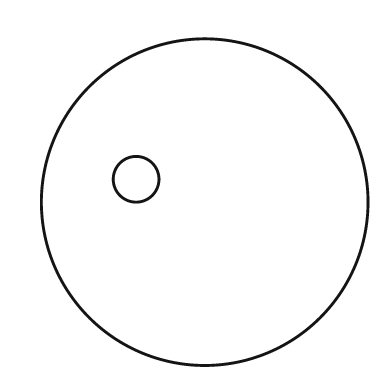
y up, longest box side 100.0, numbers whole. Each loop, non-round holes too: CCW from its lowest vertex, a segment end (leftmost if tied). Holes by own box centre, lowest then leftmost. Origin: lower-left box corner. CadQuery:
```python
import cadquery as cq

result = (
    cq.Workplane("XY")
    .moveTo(50.0, 50.0)
    .circle(50.0)
    .moveTo(29.0, 57.0)
    .circle(7.0)
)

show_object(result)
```